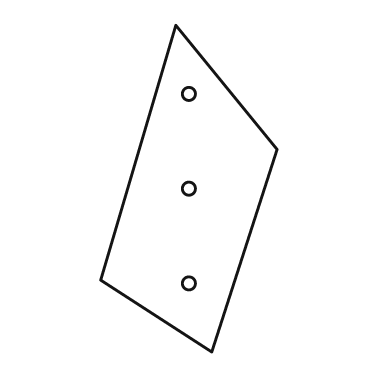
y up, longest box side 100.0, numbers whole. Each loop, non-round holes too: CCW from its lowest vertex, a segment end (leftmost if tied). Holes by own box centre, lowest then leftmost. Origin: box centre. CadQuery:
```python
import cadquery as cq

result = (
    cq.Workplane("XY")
    .moveTo(7.0, -50.0)
    .lineTo(27.0, 12.0)
    .lineTo(-4.0, 50.0)
    .lineTo(-27.0, -28.0)
    .close()
    .moveTo(0.0, -29.0)
    .circle(2.0)
    .moveTo(0.0, 0.0)
    .circle(2.0)
    .moveTo(0.0, 29.0)
    .circle(2.0)
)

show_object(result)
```